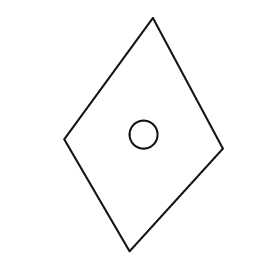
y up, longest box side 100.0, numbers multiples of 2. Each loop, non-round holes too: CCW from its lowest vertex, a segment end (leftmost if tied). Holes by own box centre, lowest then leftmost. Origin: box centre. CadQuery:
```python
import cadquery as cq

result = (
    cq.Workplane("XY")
    .moveTo(-6.0, -50.0)
    .lineTo(34.0, -6.0)
    .lineTo(4.0, 50.0)
    .lineTo(-34.0, -2.0)
    .close()
    .moveTo(0.0, 0.0)
    .circle(6.0)
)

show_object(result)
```